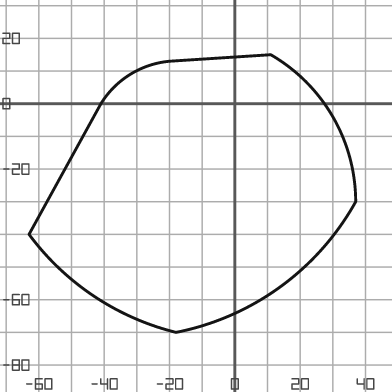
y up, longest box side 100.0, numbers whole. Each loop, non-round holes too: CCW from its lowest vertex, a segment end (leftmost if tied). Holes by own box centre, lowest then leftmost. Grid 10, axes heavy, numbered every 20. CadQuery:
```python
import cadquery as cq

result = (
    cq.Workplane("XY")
    .moveTo(-18.0, -70.0)
    .threePointArc((14.0, -56.0), (37.0, -30.0))
    .threePointArc((30.0, -4.0), (11.0, 15.0))
    .lineTo(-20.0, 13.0)
    .threePointArc((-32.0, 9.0), (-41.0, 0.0))
    .lineTo(-63.0, -40.0)
    .threePointArc((-43.0, -59.0), (-18.0, -70.0))
    .close()
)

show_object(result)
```